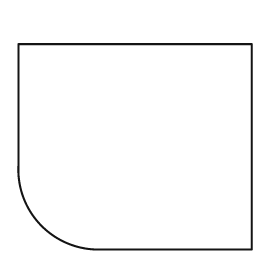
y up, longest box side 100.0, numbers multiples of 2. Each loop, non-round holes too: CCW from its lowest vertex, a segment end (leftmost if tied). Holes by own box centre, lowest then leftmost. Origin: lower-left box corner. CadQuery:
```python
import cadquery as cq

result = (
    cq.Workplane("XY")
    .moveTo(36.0, 0.0)
    .lineTo(100.0, 0.0)
    .lineTo(100.0, 88.0)
    .lineTo(0.0, 88.0)
    .lineTo(0.0, 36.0)
    .threePointArc((10.0, 10.0), (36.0, 0.0))
    .close()
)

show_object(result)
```